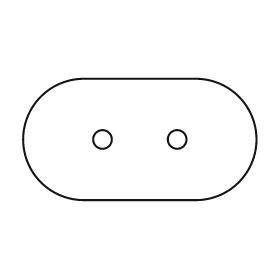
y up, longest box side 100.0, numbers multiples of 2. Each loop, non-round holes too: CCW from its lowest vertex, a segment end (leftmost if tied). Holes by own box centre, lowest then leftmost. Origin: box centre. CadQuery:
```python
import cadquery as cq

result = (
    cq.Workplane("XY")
    .moveTo(-24.0, -26.0)
    .lineTo(24.0, -26.0)
    .threePointArc((50.0, 0.0), (24.0, 26.0))
    .lineTo(-24.0, 26.0)
    .threePointArc((-50.0, 0.0), (-24.0, -26.0))
    .close()
    .moveTo(-16.0, 0.0)
    .circle(4.0)
    .moveTo(16.0, 0.0)
    .circle(4.0)
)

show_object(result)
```